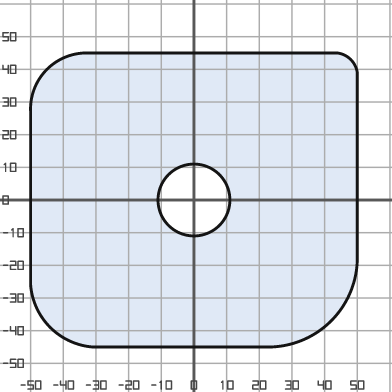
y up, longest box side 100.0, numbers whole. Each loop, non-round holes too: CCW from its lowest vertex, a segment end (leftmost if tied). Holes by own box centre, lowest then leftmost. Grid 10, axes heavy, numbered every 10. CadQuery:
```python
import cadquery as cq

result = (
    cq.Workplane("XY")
    .moveTo(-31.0, -45.0)
    .lineTo(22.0, -45.0)
    .threePointArc((42.0, -37.0), (50.0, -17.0))
    .lineTo(50.0, 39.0)
    .threePointArc((48.0, 43.0), (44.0, 45.0))
    .lineTo(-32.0, 45.0)
    .threePointArc((-45.0, 40.0), (-50.0, 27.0))
    .lineTo(-50.0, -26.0)
    .threePointArc((-44.0, -39.0), (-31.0, -45.0))
    .close()
    .moveTo(0.0, 0.0)
    .circle(11.0)
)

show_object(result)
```